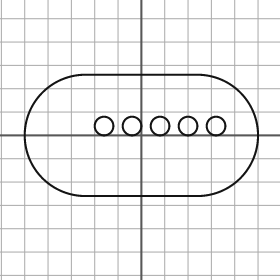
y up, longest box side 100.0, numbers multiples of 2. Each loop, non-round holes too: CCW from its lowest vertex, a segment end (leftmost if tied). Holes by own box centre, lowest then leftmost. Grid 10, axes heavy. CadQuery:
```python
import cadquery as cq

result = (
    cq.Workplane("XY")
    .moveTo(-24.0, -26.0)
    .lineTo(24.0, -26.0)
    .threePointArc((50.0, 0.0), (24.0, 26.0))
    .lineTo(-24.0, 26.0)
    .threePointArc((-50.0, 0.0), (-24.0, -26.0))
    .close()
    .moveTo(-16.0, 4.0)
    .circle(4.0)
    .moveTo(-4.0, 4.0)
    .circle(4.0)
    .moveTo(8.0, 4.0)
    .circle(4.0)
    .moveTo(20.0, 4.0)
    .circle(4.0)
    .moveTo(32.0, 4.0)
    .circle(4.0)
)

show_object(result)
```